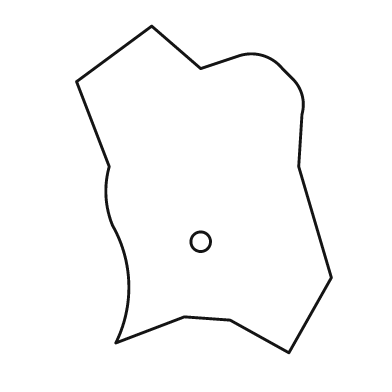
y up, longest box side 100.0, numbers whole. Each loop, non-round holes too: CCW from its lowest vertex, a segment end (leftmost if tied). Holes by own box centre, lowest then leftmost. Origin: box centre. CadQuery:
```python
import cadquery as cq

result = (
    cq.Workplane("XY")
    .moveTo(26.0, -50.0)
    .lineTo(39.0, -27.0)
    .lineTo(29.0, 7.0)
    .lineTo(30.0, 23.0)
    .threePointArc((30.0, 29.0), (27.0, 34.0))
    .lineTo(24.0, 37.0)
    .threePointArc((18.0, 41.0), (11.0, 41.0))
    .lineTo(-1.0, 37.0)
    .lineTo(-16.0, 50.0)
    .lineTo(-39.0, 33.0)
    .lineTo(-29.0, 7.0)
    .threePointArc((-30.0, -2.0), (-28.0, -11.0))
    .threePointArc((-23.0, -29.0), (-27.0, -47.0))
    .lineTo(-6.0, -39.0)
    .lineTo(8.0, -40.0)
    .close()
    .moveTo(-1.0, -16.0)
    .circle(3.0)
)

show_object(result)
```